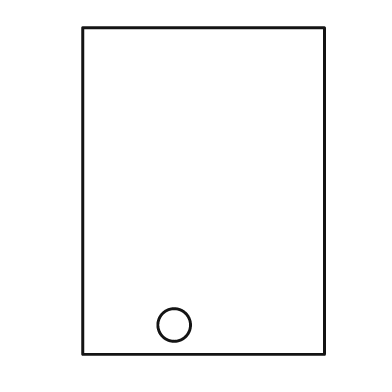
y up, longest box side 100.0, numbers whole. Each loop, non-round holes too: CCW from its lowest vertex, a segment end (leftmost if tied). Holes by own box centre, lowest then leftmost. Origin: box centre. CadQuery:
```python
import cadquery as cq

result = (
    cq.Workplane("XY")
    .moveTo(-37.0, -50.0)
    .lineTo(37.0, -50.0)
    .lineTo(37.0, 50.0)
    .lineTo(-37.0, 50.0)
    .close()
    .moveTo(-9.0, -41.0)
    .circle(5.0)
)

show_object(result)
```